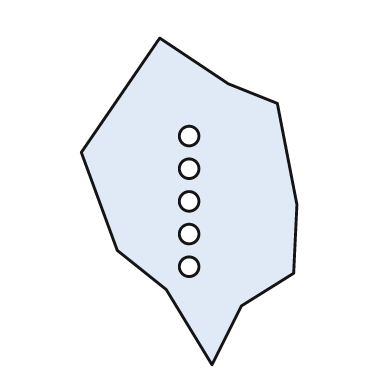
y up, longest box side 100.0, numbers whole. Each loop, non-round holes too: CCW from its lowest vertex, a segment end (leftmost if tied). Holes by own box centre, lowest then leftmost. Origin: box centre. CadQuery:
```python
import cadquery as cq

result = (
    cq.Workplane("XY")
    .moveTo(7.0, -50.0)
    .lineTo(16.0, -32.0)
    .lineTo(32.0, -22.0)
    .lineTo(33.0, -1.0)
    .lineTo(27.0, 30.0)
    .lineTo(12.0, 36.0)
    .lineTo(-9.0, 50.0)
    .lineTo(-33.0, 15.0)
    .lineTo(-22.0, -15.0)
    .lineTo(-7.0, -27.0)
    .close()
    .moveTo(0.0, -20.0)
    .circle(3.0)
    .moveTo(0.0, -10.0)
    .circle(3.0)
    .moveTo(0.0, 0.0)
    .circle(3.0)
    .moveTo(0.0, 10.0)
    .circle(3.0)
    .moveTo(0.0, 20.0)
    .circle(3.0)
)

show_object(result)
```